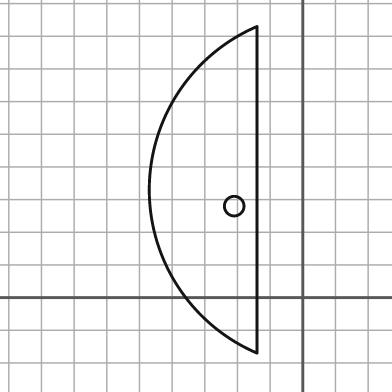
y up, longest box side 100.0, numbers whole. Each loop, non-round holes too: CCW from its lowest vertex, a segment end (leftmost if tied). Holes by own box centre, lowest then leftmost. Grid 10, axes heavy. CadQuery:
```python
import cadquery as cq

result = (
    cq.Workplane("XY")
    .moveTo(-14.0, -17.0)
    .lineTo(-14.0, 83.0)
    .threePointArc((-47.0, 33.0), (-14.0, -17.0))
    .close()
    .moveTo(-21.0, 28.0)
    .circle(3.0)
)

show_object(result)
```